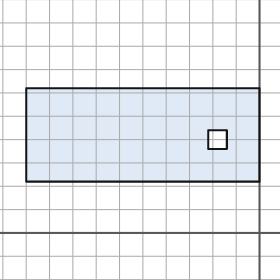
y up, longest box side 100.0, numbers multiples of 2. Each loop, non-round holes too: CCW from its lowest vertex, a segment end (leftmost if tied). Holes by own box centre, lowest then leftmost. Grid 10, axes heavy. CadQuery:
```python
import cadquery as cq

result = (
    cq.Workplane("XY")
    .moveTo(-100.0, 22.0)
    .lineTo(0.0, 22.0)
    .lineTo(0.0, 62.0)
    .lineTo(-100.0, 62.0)
    .close()
    .moveTo(-22.0, 36.0)
    .lineTo(-14.0, 36.0)
    .lineTo(-14.0, 44.0)
    .lineTo(-22.0, 44.0)
    .close()
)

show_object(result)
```